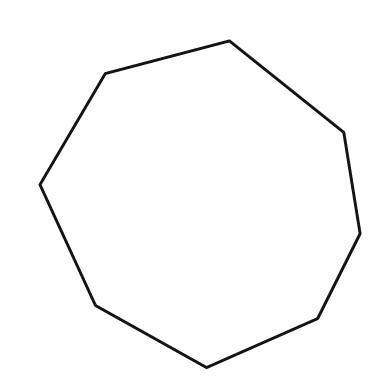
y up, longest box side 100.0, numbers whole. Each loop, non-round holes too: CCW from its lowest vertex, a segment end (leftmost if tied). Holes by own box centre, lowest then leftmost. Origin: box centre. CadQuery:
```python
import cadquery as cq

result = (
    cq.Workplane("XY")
    .moveTo(2.0, -50.0)
    .lineTo(36.0, -35.0)
    .lineTo(49.0, -9.0)
    .lineTo(44.0, 22.0)
    .lineTo(9.0, 50.0)
    .lineTo(-29.0, 40.0)
    .lineTo(-49.0, 6.0)
    .lineTo(-32.0, -31.0)
    .close()
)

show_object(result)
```